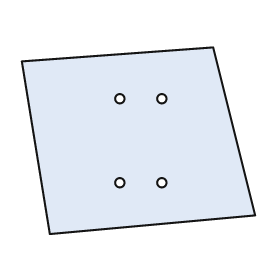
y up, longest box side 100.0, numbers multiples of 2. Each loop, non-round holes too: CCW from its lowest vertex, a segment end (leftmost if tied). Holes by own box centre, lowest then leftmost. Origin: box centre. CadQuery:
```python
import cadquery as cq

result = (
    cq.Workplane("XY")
    .moveTo(-38.0, -40.0)
    .lineTo(50.0, -32.0)
    .lineTo(32.0, 40.0)
    .lineTo(-50.0, 34.0)
    .close()
    .moveTo(-8.0, -18.0)
    .circle(2.0)
    .moveTo(10.0, -18.0)
    .circle(2.0)
    .moveTo(-8.0, 18.0)
    .circle(2.0)
    .moveTo(10.0, 18.0)
    .circle(2.0)
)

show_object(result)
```